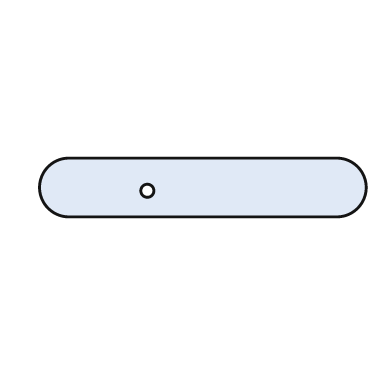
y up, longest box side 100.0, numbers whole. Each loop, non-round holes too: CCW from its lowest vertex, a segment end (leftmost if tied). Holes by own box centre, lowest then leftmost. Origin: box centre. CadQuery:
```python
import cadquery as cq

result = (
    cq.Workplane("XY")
    .moveTo(-41.0, -9.0)
    .lineTo(41.0, -9.0)
    .threePointArc((50.0, 0.0), (41.0, 9.0))
    .lineTo(-41.0, 9.0)
    .threePointArc((-50.0, 0.0), (-41.0, -9.0))
    .close()
    .moveTo(-17.0, -1.0)
    .circle(2.0)
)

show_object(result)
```